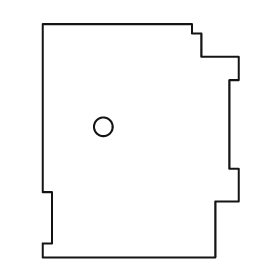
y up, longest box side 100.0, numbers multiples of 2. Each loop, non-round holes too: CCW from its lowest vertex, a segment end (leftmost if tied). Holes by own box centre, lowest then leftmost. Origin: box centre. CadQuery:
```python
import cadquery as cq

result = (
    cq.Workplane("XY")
    .moveTo(-42.0, -50.0)
    .lineTo(32.0, -50.0)
    .lineTo(32.0, -26.0)
    .lineTo(42.0, -26.0)
    .lineTo(42.0, -12.0)
    .lineTo(38.0, -12.0)
    .lineTo(38.0, 26.0)
    .lineTo(42.0, 26.0)
    .lineTo(42.0, 36.0)
    .lineTo(26.0, 36.0)
    .lineTo(26.0, 46.0)
    .lineTo(22.0, 46.0)
    .lineTo(22.0, 50.0)
    .lineTo(-42.0, 50.0)
    .lineTo(-42.0, -22.0)
    .lineTo(-38.0, -22.0)
    .lineTo(-38.0, -44.0)
    .lineTo(-42.0, -44.0)
    .close()
    .moveTo(-16.0, 6.0)
    .circle(4.0)
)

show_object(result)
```